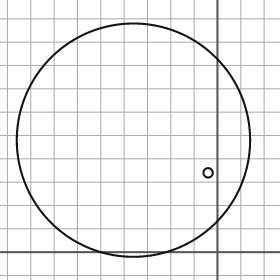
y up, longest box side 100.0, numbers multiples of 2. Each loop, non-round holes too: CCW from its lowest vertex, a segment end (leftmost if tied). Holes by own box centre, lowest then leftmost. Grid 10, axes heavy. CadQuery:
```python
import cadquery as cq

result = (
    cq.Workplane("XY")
    .moveTo(-36.0, 48.0)
    .circle(50.0)
    .moveTo(-4.0, 34.0)
    .circle(2.0)
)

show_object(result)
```